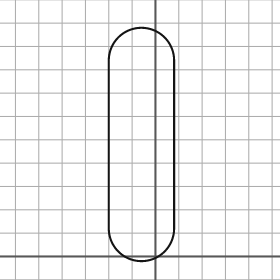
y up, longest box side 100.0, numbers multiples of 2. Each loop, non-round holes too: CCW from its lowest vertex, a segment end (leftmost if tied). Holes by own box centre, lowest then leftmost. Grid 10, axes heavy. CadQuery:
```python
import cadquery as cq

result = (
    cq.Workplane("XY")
    .moveTo(-20.0, 12.0)
    .threePointArc((-6.0, -2.0), (8.0, 12.0))
    .lineTo(8.0, 84.0)
    .threePointArc((-6.0, 98.0), (-20.0, 84.0))
    .close()
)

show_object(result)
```